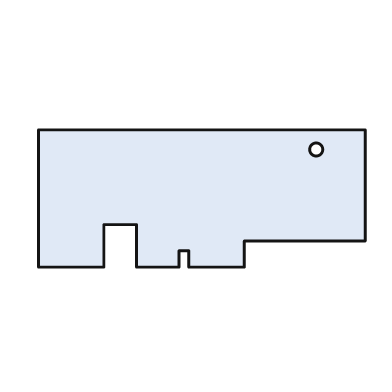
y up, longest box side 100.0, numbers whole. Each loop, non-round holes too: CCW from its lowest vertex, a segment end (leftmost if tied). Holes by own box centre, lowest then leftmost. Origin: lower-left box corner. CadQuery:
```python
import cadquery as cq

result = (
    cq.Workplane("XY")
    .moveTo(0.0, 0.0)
    .lineTo(20.0, 0.0)
    .lineTo(20.0, 13.0)
    .lineTo(30.0, 13.0)
    .lineTo(30.0, 0.0)
    .lineTo(43.0, 0.0)
    .lineTo(43.0, 5.0)
    .lineTo(46.0, 5.0)
    .lineTo(46.0, 0.0)
    .lineTo(63.0, 0.0)
    .lineTo(63.0, 8.0)
    .lineTo(100.0, 8.0)
    .lineTo(100.0, 42.0)
    .lineTo(0.0, 42.0)
    .close()
    .moveTo(85.0, 36.0)
    .circle(2.0)
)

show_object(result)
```